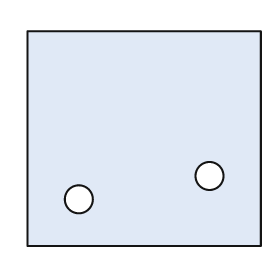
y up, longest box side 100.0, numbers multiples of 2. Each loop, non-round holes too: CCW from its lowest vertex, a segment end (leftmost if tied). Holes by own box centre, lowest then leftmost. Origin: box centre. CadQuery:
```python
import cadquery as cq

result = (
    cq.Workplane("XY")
    .moveTo(-50.0, -46.0)
    .lineTo(50.0, -46.0)
    .lineTo(50.0, 46.0)
    .lineTo(-50.0, 46.0)
    .close()
    .moveTo(-28.0, -26.0)
    .circle(6.0)
    .moveTo(28.0, -16.0)
    .circle(6.0)
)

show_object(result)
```